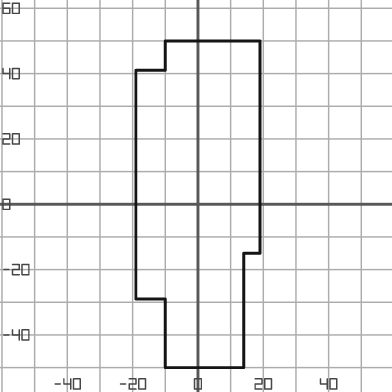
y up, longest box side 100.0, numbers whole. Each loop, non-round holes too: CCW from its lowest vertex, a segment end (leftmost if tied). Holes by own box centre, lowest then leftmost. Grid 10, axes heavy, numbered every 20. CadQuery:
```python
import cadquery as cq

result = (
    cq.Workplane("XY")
    .moveTo(-10.0, -50.0)
    .lineTo(14.0, -50.0)
    .lineTo(14.0, -15.0)
    .lineTo(19.0, -15.0)
    .lineTo(19.0, 50.0)
    .lineTo(-10.0, 50.0)
    .lineTo(-10.0, 41.0)
    .lineTo(-19.0, 41.0)
    .lineTo(-19.0, -29.0)
    .lineTo(-10.0, -29.0)
    .close()
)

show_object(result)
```